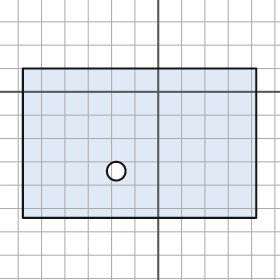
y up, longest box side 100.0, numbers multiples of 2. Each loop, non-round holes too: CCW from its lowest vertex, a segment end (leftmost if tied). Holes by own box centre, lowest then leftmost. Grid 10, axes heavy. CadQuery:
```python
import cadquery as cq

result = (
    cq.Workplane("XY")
    .moveTo(-58.0, -54.0)
    .lineTo(42.0, -54.0)
    .lineTo(42.0, 10.0)
    .lineTo(-58.0, 10.0)
    .close()
    .moveTo(-18.0, -34.0)
    .circle(4.0)
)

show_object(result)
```